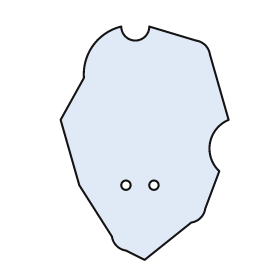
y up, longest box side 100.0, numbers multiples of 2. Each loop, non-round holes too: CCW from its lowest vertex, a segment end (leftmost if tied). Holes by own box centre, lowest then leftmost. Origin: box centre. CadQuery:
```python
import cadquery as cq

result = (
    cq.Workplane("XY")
    .moveTo(0.0, -50.0)
    .lineTo(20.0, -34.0)
    .threePointArc((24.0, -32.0), (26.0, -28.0))
    .lineTo(32.0, -12.0)
    .threePointArc((28.0, 0.0), (36.0, 10.0))
    .lineTo(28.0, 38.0)
    .threePointArc((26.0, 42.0), (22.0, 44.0))
    .lineTo(2.0, 50.0)
    .threePointArc((-4.0, 44.0), (-10.0, 50.0))
    .threePointArc((-22.0, 42.0), (-26.0, 28.0))
    .lineTo(-36.0, 10.0)
    .lineTo(-28.0, -18.0)
    .lineTo(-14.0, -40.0)
    .threePointArc((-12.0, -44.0), (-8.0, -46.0))
    .close()
    .moveTo(-8.0, -18.0)
    .circle(2.0)
    .moveTo(4.0, -18.0)
    .circle(2.0)
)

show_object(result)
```